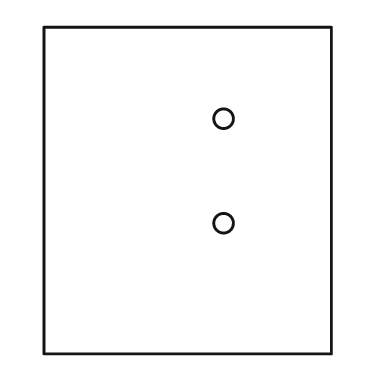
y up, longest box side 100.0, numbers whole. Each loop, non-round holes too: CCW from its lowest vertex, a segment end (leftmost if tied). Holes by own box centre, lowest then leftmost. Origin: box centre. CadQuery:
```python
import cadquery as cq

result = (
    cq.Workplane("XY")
    .moveTo(-44.0, -50.0)
    .lineTo(44.0, -50.0)
    .lineTo(44.0, 50.0)
    .lineTo(-44.0, 50.0)
    .close()
    .moveTo(11.0, -10.0)
    .circle(3.0)
    .moveTo(11.0, 22.0)
    .circle(3.0)
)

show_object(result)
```